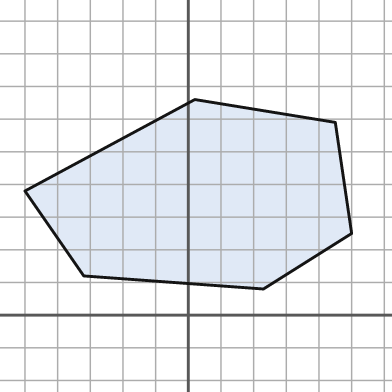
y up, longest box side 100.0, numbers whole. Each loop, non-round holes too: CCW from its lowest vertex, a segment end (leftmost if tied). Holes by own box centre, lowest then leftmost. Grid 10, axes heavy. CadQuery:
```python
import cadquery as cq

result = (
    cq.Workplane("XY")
    .moveTo(23.0, 8.0)
    .lineTo(50.0, 25.0)
    .lineTo(45.0, 59.0)
    .lineTo(2.0, 66.0)
    .lineTo(-50.0, 38.0)
    .lineTo(-32.0, 12.0)
    .close()
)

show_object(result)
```